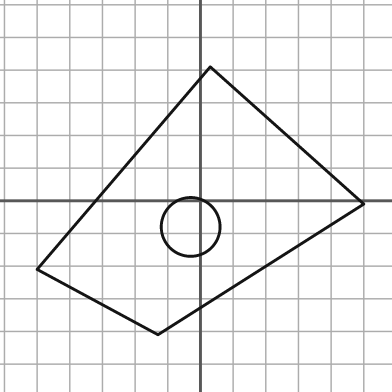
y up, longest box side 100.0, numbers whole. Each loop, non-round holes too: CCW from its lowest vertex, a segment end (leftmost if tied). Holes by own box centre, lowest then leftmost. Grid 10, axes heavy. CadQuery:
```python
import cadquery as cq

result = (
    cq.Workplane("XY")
    .moveTo(-13.0, -41.0)
    .lineTo(50.0, -1.0)
    .lineTo(3.0, 41.0)
    .lineTo(-50.0, -21.0)
    .close()
    .moveTo(-3.0, -8.0)
    .circle(9.0)
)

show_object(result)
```